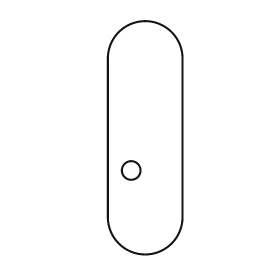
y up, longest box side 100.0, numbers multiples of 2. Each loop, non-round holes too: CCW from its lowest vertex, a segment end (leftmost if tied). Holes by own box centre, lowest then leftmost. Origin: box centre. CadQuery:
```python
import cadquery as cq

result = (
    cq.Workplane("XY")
    .moveTo(-16.0, -34.0)
    .threePointArc((0.0, -50.0), (16.0, -34.0))
    .lineTo(16.0, 34.0)
    .threePointArc((0.0, 50.0), (-16.0, 34.0))
    .close()
    .moveTo(-6.0, -14.0)
    .circle(4.0)
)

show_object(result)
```